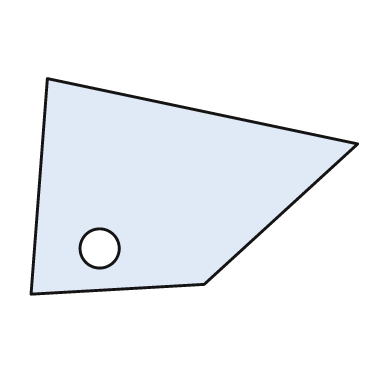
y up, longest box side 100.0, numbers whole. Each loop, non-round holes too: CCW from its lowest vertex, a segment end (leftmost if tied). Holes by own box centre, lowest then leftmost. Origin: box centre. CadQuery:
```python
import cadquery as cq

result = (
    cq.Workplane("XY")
    .moveTo(-50.0, -33.0)
    .lineTo(3.0, -30.0)
    .lineTo(50.0, 13.0)
    .lineTo(-45.0, 33.0)
    .close()
    .moveTo(-29.0, -19.0)
    .circle(6.0)
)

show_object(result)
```